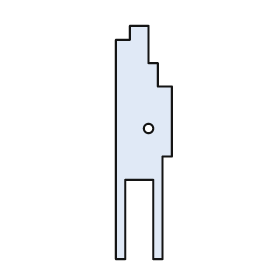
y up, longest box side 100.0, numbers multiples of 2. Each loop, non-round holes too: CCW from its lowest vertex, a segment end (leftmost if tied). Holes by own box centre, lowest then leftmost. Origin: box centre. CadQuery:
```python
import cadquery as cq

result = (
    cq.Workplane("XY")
    .moveTo(-12.0, -50.0)
    .lineTo(-8.0, -50.0)
    .lineTo(-8.0, -16.0)
    .lineTo(4.0, -16.0)
    .lineTo(4.0, -50.0)
    .lineTo(8.0, -50.0)
    .lineTo(8.0, -6.0)
    .lineTo(12.0, -6.0)
    .lineTo(12.0, 24.0)
    .lineTo(6.0, 24.0)
    .lineTo(6.0, 34.0)
    .lineTo(2.0, 34.0)
    .lineTo(2.0, 50.0)
    .lineTo(-6.0, 50.0)
    .lineTo(-6.0, 44.0)
    .lineTo(-12.0, 44.0)
    .close()
    .moveTo(2.0, 6.0)
    .circle(2.0)
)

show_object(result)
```